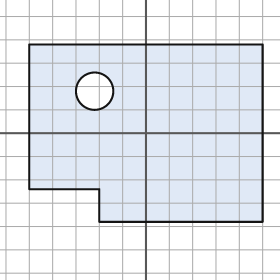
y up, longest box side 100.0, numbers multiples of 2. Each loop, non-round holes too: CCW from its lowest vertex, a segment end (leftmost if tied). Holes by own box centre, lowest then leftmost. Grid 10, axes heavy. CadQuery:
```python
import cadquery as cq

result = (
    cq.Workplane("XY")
    .moveTo(-20.0, -38.0)
    .lineTo(50.0, -38.0)
    .lineTo(50.0, 38.0)
    .lineTo(-50.0, 38.0)
    .lineTo(-50.0, -24.0)
    .lineTo(-20.0, -24.0)
    .close()
    .moveTo(-22.0, 18.0)
    .circle(8.0)
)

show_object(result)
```